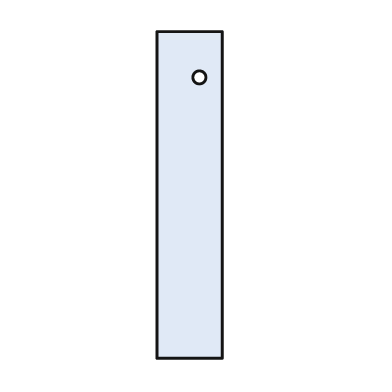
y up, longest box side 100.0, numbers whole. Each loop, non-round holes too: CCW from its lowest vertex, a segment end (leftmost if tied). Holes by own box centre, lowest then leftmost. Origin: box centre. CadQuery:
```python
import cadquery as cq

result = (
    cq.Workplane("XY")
    .moveTo(-10.0, -50.0)
    .lineTo(10.0, -50.0)
    .lineTo(10.0, 50.0)
    .lineTo(-10.0, 50.0)
    .close()
    .moveTo(3.0, 36.0)
    .circle(2.0)
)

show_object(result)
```